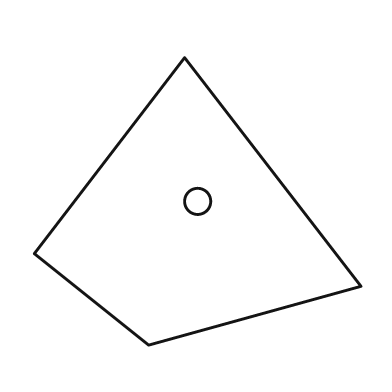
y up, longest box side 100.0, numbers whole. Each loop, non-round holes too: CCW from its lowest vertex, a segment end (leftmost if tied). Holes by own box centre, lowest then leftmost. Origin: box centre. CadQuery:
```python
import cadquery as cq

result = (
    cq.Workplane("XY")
    .moveTo(-15.0, -44.0)
    .lineTo(50.0, -26.0)
    .lineTo(-4.0, 44.0)
    .lineTo(-50.0, -16.0)
    .close()
    .moveTo(0.0, 0.0)
    .circle(4.0)
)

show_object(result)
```